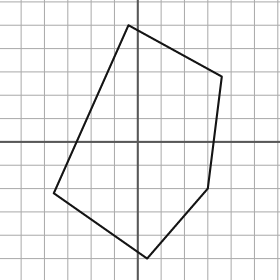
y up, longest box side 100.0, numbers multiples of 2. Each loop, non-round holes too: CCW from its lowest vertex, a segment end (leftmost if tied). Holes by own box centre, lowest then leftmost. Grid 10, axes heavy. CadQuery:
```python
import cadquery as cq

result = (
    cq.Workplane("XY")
    .moveTo(4.0, -50.0)
    .lineTo(30.0, -20.0)
    .lineTo(36.0, 28.0)
    .lineTo(-4.0, 50.0)
    .lineTo(-36.0, -22.0)
    .close()
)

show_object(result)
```